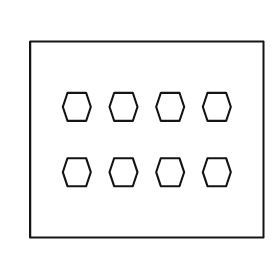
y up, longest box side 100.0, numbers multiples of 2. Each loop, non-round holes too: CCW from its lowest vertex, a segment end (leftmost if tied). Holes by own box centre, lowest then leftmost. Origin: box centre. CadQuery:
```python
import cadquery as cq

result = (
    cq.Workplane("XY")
    .moveTo(-50.0, -42.0)
    .lineTo(50.0, -42.0)
    .lineTo(50.0, 42.0)
    .lineTo(-50.0, 42.0)
    .close()
    .moveTo(-34.0, -20.0)
    .lineTo(-26.0, -20.0)
    .lineTo(-24.0, -14.0)
    .lineTo(-26.0, -8.0)
    .lineTo(-34.0, -8.0)
    .lineTo(-36.0, -14.0)
    .close()
    .moveTo(-14.0, -20.0)
    .lineTo(-6.0, -20.0)
    .lineTo(-4.0, -14.0)
    .lineTo(-6.0, -8.0)
    .lineTo(-14.0, -8.0)
    .lineTo(-16.0, -14.0)
    .close()
    .moveTo(6.0, -20.0)
    .lineTo(14.0, -20.0)
    .lineTo(16.0, -14.0)
    .lineTo(14.0, -8.0)
    .lineTo(6.0, -8.0)
    .lineTo(4.0, -14.0)
    .close()
    .moveTo(26.0, -20.0)
    .lineTo(34.0, -20.0)
    .lineTo(36.0, -14.0)
    .lineTo(34.0, -8.0)
    .lineTo(26.0, -8.0)
    .lineTo(24.0, -14.0)
    .close()
    .moveTo(-34.0, 8.0)
    .lineTo(-26.0, 8.0)
    .lineTo(-24.0, 14.0)
    .lineTo(-26.0, 20.0)
    .lineTo(-34.0, 20.0)
    .lineTo(-36.0, 14.0)
    .close()
    .moveTo(-14.0, 8.0)
    .lineTo(-6.0, 8.0)
    .lineTo(-4.0, 14.0)
    .lineTo(-6.0, 20.0)
    .lineTo(-14.0, 20.0)
    .lineTo(-16.0, 14.0)
    .close()
    .moveTo(6.0, 8.0)
    .lineTo(14.0, 8.0)
    .lineTo(16.0, 14.0)
    .lineTo(14.0, 20.0)
    .lineTo(6.0, 20.0)
    .lineTo(4.0, 14.0)
    .close()
    .moveTo(26.0, 8.0)
    .lineTo(34.0, 8.0)
    .lineTo(36.0, 14.0)
    .lineTo(34.0, 20.0)
    .lineTo(26.0, 20.0)
    .lineTo(24.0, 14.0)
    .close()
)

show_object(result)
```